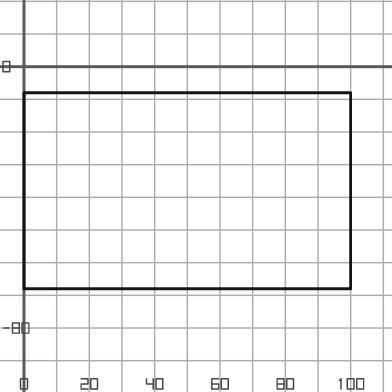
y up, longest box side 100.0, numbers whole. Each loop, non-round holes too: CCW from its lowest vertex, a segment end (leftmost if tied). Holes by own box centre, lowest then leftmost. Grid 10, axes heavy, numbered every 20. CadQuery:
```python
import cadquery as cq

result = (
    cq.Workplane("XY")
    .moveTo(0.0, -68.0)
    .lineTo(100.0, -68.0)
    .lineTo(100.0, -8.0)
    .lineTo(0.0, -8.0)
    .close()
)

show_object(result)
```